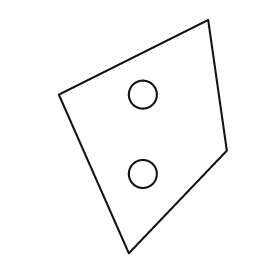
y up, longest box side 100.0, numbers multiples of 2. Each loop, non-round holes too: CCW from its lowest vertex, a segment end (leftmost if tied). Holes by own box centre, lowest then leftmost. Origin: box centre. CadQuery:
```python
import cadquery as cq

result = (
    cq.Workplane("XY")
    .moveTo(-6.0, -50.0)
    .lineTo(36.0, -6.0)
    .lineTo(28.0, 50.0)
    .lineTo(-36.0, 18.0)
    .close()
    .moveTo(0.0, -16.0)
    .circle(6.0)
    .moveTo(0.0, 18.0)
    .circle(6.0)
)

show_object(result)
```